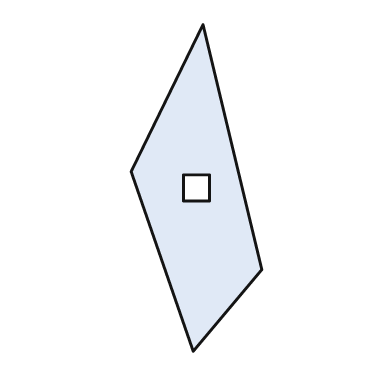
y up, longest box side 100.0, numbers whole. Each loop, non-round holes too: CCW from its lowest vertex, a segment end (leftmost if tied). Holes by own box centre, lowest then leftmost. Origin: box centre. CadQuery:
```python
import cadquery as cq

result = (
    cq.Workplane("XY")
    .moveTo(-1.0, -50.0)
    .lineTo(20.0, -25.0)
    .lineTo(2.0, 50.0)
    .lineTo(-20.0, 5.0)
    .close()
    .moveTo(-4.0, -4.0)
    .lineTo(4.0, -4.0)
    .lineTo(4.0, 4.0)
    .lineTo(-4.0, 4.0)
    .close()
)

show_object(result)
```